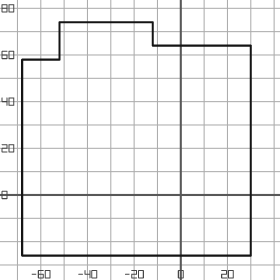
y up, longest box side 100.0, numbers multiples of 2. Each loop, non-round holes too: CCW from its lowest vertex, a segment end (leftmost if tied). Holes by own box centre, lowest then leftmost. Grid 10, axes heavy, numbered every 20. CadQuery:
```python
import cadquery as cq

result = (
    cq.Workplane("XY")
    .moveTo(-68.0, -26.0)
    .lineTo(30.0, -26.0)
    .lineTo(30.0, 64.0)
    .lineTo(-12.0, 64.0)
    .lineTo(-12.0, 74.0)
    .lineTo(-52.0, 74.0)
    .lineTo(-52.0, 58.0)
    .lineTo(-68.0, 58.0)
    .close()
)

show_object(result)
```